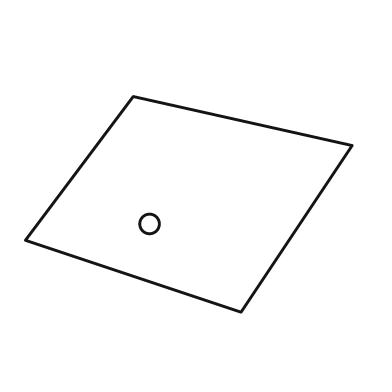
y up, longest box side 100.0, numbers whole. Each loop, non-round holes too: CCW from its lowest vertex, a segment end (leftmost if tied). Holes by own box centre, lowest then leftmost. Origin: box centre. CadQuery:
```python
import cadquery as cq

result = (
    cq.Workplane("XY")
    .moveTo(16.0, -33.0)
    .lineTo(50.0, 18.0)
    .lineTo(-17.0, 33.0)
    .lineTo(-50.0, -11.0)
    .close()
    .moveTo(-12.0, -6.0)
    .circle(3.0)
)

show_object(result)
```